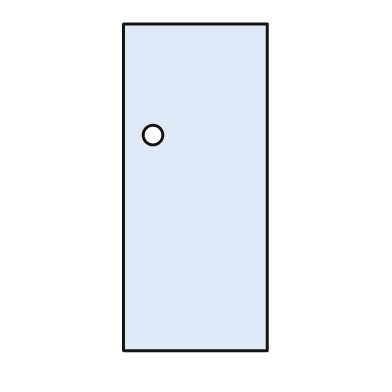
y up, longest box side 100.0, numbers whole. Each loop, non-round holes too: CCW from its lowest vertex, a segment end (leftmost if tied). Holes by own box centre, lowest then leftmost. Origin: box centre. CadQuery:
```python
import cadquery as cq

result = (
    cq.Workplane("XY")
    .moveTo(-22.0, -50.0)
    .lineTo(22.0, -50.0)
    .lineTo(22.0, 50.0)
    .lineTo(-22.0, 50.0)
    .close()
    .moveTo(-13.0, 16.0)
    .circle(3.0)
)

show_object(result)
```